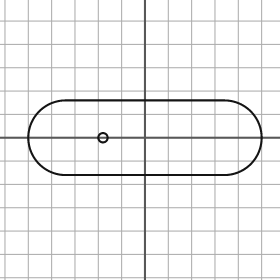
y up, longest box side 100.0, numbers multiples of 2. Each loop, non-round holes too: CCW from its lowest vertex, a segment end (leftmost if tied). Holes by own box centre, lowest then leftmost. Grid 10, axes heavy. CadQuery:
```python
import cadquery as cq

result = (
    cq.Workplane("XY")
    .moveTo(-34.0, -16.0)
    .lineTo(34.0, -16.0)
    .threePointArc((50.0, 0.0), (34.0, 16.0))
    .lineTo(-34.0, 16.0)
    .threePointArc((-50.0, 0.0), (-34.0, -16.0))
    .close()
    .moveTo(-18.0, 0.0)
    .circle(2.0)
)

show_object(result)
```